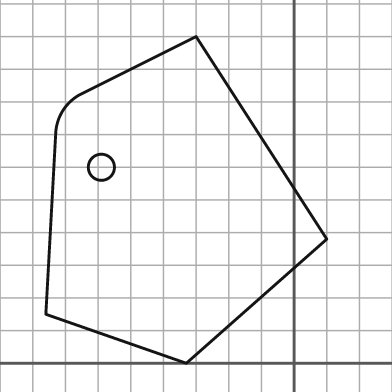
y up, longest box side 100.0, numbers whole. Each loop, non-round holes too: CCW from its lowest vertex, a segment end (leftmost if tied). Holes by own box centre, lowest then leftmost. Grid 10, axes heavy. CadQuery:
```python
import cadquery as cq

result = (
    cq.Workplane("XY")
    .moveTo(-33.0, 0.0)
    .lineTo(10.0, 38.0)
    .lineTo(-30.0, 100.0)
    .lineTo(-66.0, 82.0)
    .threePointArc((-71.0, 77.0), (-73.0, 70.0))
    .lineTo(-76.0, 15.0)
    .close()
    .moveTo(-59.0, 60.0)
    .circle(4.0)
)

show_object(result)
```